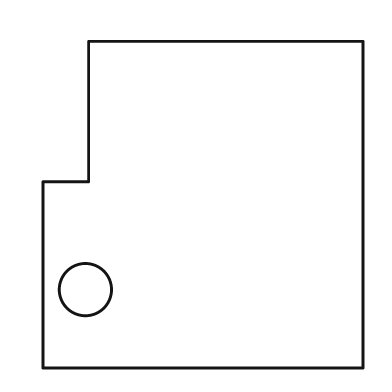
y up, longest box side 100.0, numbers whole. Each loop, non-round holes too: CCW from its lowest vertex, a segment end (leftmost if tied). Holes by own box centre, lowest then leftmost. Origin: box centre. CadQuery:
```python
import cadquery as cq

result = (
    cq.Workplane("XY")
    .moveTo(-49.0, -50.0)
    .lineTo(49.0, -50.0)
    .lineTo(49.0, 50.0)
    .lineTo(-35.0, 50.0)
    .lineTo(-35.0, 7.0)
    .lineTo(-49.0, 7.0)
    .close()
    .moveTo(-36.0, -26.0)
    .circle(8.0)
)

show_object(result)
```